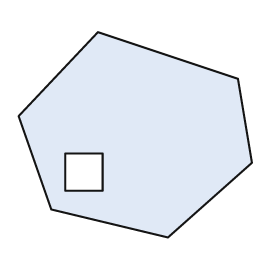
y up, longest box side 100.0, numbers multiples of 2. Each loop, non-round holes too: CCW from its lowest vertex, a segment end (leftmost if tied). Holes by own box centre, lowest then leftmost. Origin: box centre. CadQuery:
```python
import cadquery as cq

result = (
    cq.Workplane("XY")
    .moveTo(14.0, -44.0)
    .lineTo(50.0, -12.0)
    .lineTo(44.0, 24.0)
    .lineTo(-16.0, 44.0)
    .lineTo(-50.0, 8.0)
    .lineTo(-36.0, -32.0)
    .close()
    .moveTo(-30.0, -24.0)
    .lineTo(-14.0, -24.0)
    .lineTo(-14.0, -8.0)
    .lineTo(-30.0, -8.0)
    .close()
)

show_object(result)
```